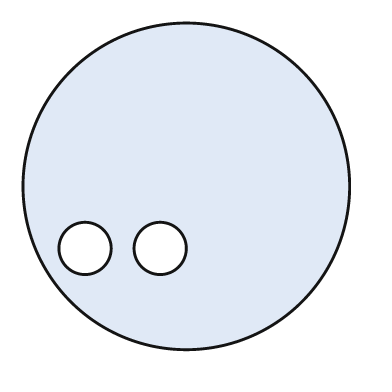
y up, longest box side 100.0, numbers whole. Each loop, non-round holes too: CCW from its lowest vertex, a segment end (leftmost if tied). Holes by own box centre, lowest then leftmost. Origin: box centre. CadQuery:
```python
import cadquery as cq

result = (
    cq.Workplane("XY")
    .moveTo(0.0, 0.0)
    .circle(50.0)
    .moveTo(-31.0, -19.0)
    .circle(8.0)
    .moveTo(-8.0, -19.0)
    .circle(8.0)
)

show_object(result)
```